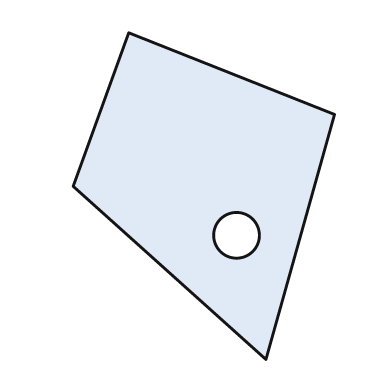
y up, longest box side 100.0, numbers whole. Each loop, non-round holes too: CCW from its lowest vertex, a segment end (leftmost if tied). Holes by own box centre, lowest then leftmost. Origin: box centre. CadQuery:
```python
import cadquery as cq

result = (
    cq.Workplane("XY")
    .moveTo(19.0, -50.0)
    .lineTo(40.0, 25.0)
    .lineTo(-23.0, 50.0)
    .lineTo(-40.0, 3.0)
    .close()
    .moveTo(10.0, -12.0)
    .circle(7.0)
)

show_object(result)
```